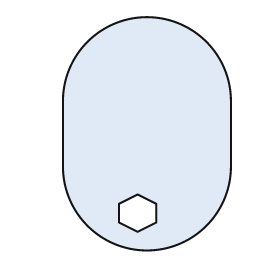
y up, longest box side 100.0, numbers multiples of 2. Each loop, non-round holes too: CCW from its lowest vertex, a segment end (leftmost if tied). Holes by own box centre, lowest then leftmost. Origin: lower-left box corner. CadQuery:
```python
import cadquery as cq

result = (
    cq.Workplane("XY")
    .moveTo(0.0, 36.0)
    .threePointArc((36.0, 0.0), (72.0, 36.0))
    .lineTo(72.0, 64.0)
    .threePointArc((36.0, 100.0), (0.0, 64.0))
    .close()
    .moveTo(32.0, 8.0)
    .lineTo(40.0, 12.0)
    .lineTo(40.0, 20.0)
    .lineTo(32.0, 24.0)
    .lineTo(24.0, 20.0)
    .lineTo(24.0, 12.0)
    .close()
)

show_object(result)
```